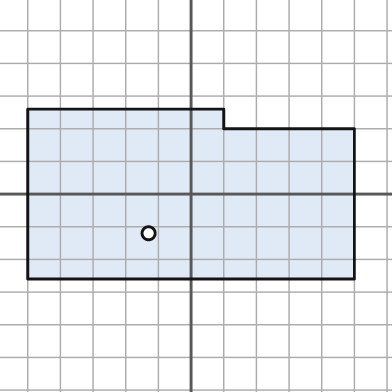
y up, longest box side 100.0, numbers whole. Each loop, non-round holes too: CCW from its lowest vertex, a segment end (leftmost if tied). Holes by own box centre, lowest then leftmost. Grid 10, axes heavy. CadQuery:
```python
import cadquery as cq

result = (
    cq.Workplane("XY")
    .moveTo(-50.0, -26.0)
    .lineTo(50.0, -26.0)
    .lineTo(50.0, 20.0)
    .lineTo(10.0, 20.0)
    .lineTo(10.0, 26.0)
    .lineTo(-50.0, 26.0)
    .close()
    .moveTo(-13.0, -12.0)
    .circle(2.0)
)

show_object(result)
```